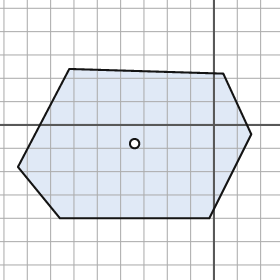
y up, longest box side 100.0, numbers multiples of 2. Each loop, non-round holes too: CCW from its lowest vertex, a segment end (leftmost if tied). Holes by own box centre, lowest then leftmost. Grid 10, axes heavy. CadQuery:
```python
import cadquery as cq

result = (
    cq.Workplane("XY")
    .moveTo(-66.0, -40.0)
    .lineTo(-2.0, -40.0)
    .lineTo(16.0, -4.0)
    .lineTo(4.0, 22.0)
    .lineTo(-62.0, 24.0)
    .lineTo(-84.0, -18.0)
    .close()
    .moveTo(-34.0, -8.0)
    .circle(2.0)
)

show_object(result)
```